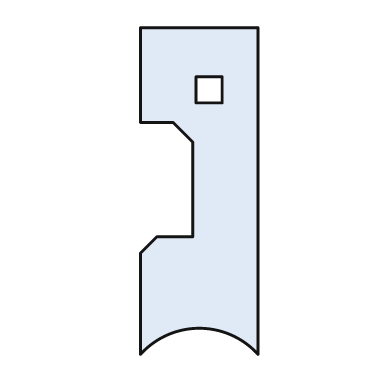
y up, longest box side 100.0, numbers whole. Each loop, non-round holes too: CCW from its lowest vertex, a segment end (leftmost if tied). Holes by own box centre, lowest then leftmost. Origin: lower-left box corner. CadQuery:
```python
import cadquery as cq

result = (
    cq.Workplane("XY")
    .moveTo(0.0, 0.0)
    .threePointArc((18.0, 8.0), (36.0, 0.0))
    .lineTo(36.0, 100.0)
    .lineTo(0.0, 100.0)
    .lineTo(0.0, 71.0)
    .lineTo(10.0, 71.0)
    .lineTo(16.0, 65.0)
    .lineTo(16.0, 36.0)
    .lineTo(5.0, 36.0)
    .lineTo(0.0, 31.0)
    .close()
    .moveTo(17.0, 77.0)
    .lineTo(25.0, 77.0)
    .lineTo(25.0, 85.0)
    .lineTo(17.0, 85.0)
    .close()
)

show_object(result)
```